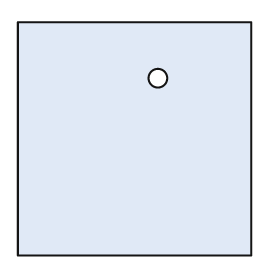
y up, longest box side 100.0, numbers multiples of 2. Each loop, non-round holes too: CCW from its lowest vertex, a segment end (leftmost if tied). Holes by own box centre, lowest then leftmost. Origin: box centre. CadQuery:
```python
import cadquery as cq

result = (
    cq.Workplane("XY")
    .moveTo(-50.0, -50.0)
    .lineTo(50.0, -50.0)
    .lineTo(50.0, 50.0)
    .lineTo(-50.0, 50.0)
    .close()
    .moveTo(10.0, 26.0)
    .circle(4.0)
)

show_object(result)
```